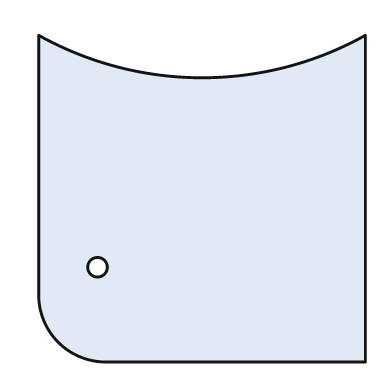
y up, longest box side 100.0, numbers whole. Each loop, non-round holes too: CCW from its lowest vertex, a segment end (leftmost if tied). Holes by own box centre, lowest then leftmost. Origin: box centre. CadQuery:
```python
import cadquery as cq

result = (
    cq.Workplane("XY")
    .moveTo(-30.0, -50.0)
    .lineTo(50.0, -50.0)
    .lineTo(50.0, 50.0)
    .threePointArc((0.0, 37.0), (-50.0, 50.0))
    .lineTo(-50.0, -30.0)
    .threePointArc((-44.0, -44.0), (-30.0, -50.0))
    .close()
    .moveTo(-32.0, -21.0)
    .circle(3.0)
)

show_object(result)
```